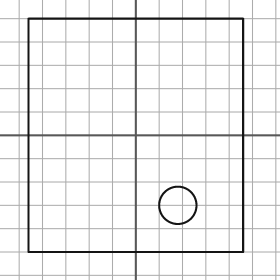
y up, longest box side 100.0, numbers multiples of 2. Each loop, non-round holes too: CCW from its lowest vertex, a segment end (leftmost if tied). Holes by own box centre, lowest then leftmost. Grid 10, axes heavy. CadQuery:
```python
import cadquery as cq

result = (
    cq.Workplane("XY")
    .moveTo(-46.0, -50.0)
    .lineTo(46.0, -50.0)
    .lineTo(46.0, 50.0)
    .lineTo(-46.0, 50.0)
    .close()
    .moveTo(18.0, -30.0)
    .circle(8.0)
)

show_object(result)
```